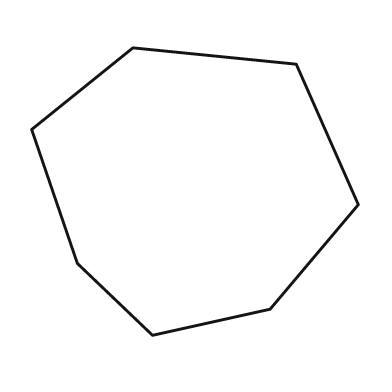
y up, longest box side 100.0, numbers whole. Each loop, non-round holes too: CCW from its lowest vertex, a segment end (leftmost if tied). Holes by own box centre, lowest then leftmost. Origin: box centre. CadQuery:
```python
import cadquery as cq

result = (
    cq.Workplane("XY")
    .moveTo(-13.0, -44.0)
    .lineTo(23.0, -36.0)
    .lineTo(50.0, -4.0)
    .lineTo(31.0, 39.0)
    .lineTo(-19.0, 44.0)
    .lineTo(-50.0, 19.0)
    .lineTo(-36.0, -22.0)
    .close()
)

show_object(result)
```